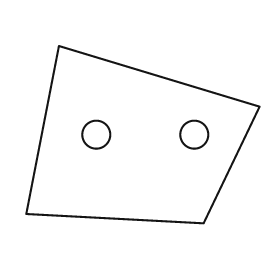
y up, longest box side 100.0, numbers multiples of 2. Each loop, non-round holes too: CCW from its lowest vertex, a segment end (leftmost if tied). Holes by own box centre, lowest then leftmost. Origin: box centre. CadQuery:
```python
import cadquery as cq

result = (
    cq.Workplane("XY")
    .moveTo(26.0, -38.0)
    .lineTo(50.0, 12.0)
    .lineTo(-36.0, 38.0)
    .lineTo(-50.0, -34.0)
    .close()
    .moveTo(-20.0, 0.0)
    .circle(6.0)
    .moveTo(22.0, 0.0)
    .circle(6.0)
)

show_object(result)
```